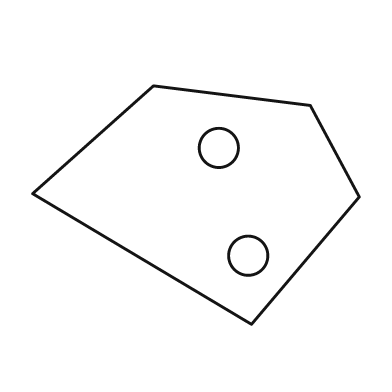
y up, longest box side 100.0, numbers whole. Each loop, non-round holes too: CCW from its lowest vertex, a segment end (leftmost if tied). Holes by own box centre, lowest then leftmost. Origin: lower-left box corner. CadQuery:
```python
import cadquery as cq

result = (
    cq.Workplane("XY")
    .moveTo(67.0, 0.0)
    .lineTo(100.0, 39.0)
    .lineTo(85.0, 67.0)
    .lineTo(37.0, 73.0)
    .lineTo(0.0, 40.0)
    .close()
    .moveTo(66.0, 21.0)
    .circle(6.0)
    .moveTo(57.0, 54.0)
    .circle(6.0)
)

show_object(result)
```